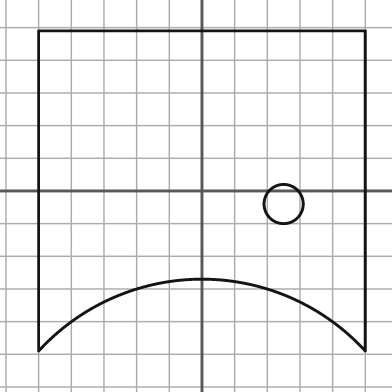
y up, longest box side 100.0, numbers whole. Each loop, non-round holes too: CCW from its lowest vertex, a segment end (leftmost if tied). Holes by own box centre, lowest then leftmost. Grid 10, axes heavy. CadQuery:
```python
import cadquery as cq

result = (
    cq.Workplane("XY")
    .moveTo(-50.0, -49.0)
    .threePointArc((0.0, -27.0), (50.0, -49.0))
    .lineTo(50.0, 49.0)
    .lineTo(-50.0, 49.0)
    .close()
    .moveTo(25.0, -4.0)
    .circle(6.0)
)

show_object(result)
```